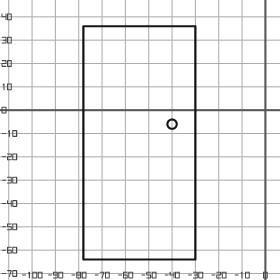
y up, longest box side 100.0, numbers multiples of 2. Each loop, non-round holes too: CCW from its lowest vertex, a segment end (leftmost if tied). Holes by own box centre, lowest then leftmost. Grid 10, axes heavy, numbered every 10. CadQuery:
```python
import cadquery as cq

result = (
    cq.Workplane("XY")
    .moveTo(-78.0, -64.0)
    .lineTo(-30.0, -64.0)
    .lineTo(-30.0, 36.0)
    .lineTo(-78.0, 36.0)
    .close()
    .moveTo(-40.0, -6.0)
    .circle(2.0)
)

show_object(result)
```